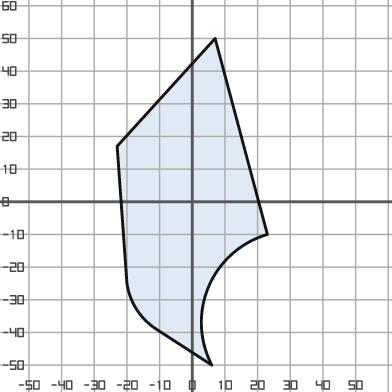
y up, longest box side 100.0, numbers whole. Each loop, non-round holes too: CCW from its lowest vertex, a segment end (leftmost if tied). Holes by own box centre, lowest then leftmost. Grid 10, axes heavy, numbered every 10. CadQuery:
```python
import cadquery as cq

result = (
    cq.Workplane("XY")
    .moveTo(6.0, -50.0)
    .threePointArc((5.0, -26.0), (23.0, -10.0))
    .lineTo(7.0, 50.0)
    .lineTo(-23.0, 17.0)
    .lineTo(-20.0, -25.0)
    .threePointArc((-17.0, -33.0), (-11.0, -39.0))
    .close()
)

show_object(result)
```